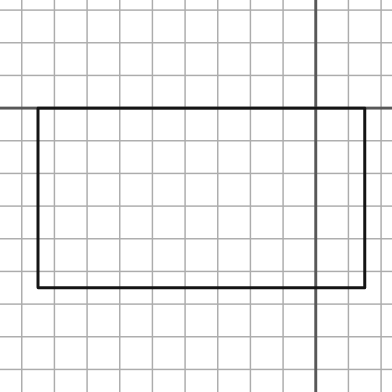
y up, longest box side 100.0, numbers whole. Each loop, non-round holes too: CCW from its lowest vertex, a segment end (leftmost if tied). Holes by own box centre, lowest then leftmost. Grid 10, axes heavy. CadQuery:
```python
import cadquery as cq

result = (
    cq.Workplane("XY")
    .moveTo(-85.0, -55.0)
    .lineTo(15.0, -55.0)
    .lineTo(15.0, 0.0)
    .lineTo(-85.0, 0.0)
    .close()
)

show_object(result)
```